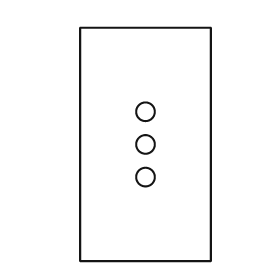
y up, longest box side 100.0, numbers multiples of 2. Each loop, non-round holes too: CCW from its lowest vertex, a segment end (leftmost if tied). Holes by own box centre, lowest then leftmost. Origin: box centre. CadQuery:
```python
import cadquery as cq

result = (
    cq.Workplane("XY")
    .moveTo(-28.0, -50.0)
    .lineTo(28.0, -50.0)
    .lineTo(28.0, 50.0)
    .lineTo(-28.0, 50.0)
    .close()
    .moveTo(0.0, -14.0)
    .circle(4.0)
    .moveTo(0.0, 0.0)
    .circle(4.0)
    .moveTo(0.0, 14.0)
    .circle(4.0)
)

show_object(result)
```